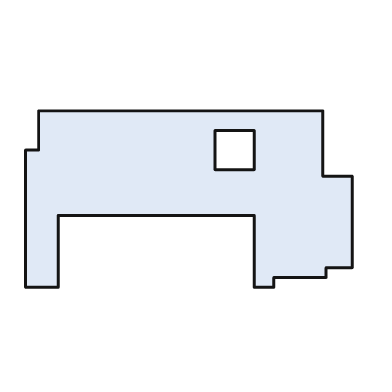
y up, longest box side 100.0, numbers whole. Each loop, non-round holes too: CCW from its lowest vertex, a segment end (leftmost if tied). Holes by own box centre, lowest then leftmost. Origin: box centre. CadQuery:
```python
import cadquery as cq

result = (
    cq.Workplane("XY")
    .moveTo(-50.0, -27.0)
    .lineTo(-40.0, -27.0)
    .lineTo(-40.0, -5.0)
    .lineTo(20.0, -5.0)
    .lineTo(20.0, -27.0)
    .lineTo(26.0, -27.0)
    .lineTo(26.0, -24.0)
    .lineTo(42.0, -24.0)
    .lineTo(42.0, -21.0)
    .lineTo(50.0, -21.0)
    .lineTo(50.0, 7.0)
    .lineTo(41.0, 7.0)
    .lineTo(41.0, 27.0)
    .lineTo(-46.0, 27.0)
    .lineTo(-46.0, 15.0)
    .lineTo(-50.0, 15.0)
    .close()
    .moveTo(8.0, 9.0)
    .lineTo(20.0, 9.0)
    .lineTo(20.0, 21.0)
    .lineTo(8.0, 21.0)
    .close()
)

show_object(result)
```